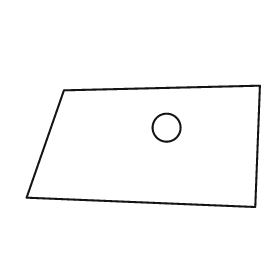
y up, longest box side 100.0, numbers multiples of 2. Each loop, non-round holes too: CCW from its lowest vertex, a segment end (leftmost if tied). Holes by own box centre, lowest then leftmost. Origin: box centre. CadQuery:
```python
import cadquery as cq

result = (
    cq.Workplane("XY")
    .moveTo(48.0, -26.0)
    .lineTo(50.0, 26.0)
    .lineTo(-34.0, 24.0)
    .lineTo(-50.0, -22.0)
    .close()
    .moveTo(10.0, 8.0)
    .circle(6.0)
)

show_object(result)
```